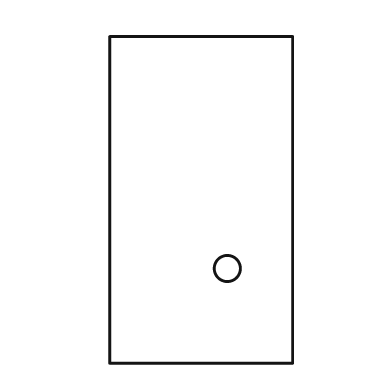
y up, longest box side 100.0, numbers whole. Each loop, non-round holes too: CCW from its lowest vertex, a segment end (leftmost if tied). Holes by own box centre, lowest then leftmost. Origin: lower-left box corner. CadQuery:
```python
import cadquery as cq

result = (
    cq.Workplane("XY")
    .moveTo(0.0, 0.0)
    .lineTo(56.0, 0.0)
    .lineTo(56.0, 100.0)
    .lineTo(0.0, 100.0)
    .close()
    .moveTo(36.0, 29.0)
    .circle(4.0)
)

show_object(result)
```